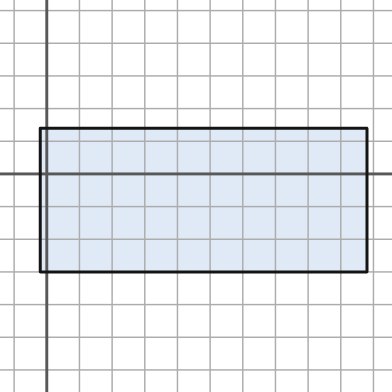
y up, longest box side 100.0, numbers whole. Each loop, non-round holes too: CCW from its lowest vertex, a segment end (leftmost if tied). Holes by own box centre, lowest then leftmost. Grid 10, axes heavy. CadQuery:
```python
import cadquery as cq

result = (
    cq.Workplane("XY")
    .moveTo(-2.0, -30.0)
    .lineTo(98.0, -30.0)
    .lineTo(98.0, 14.0)
    .lineTo(-2.0, 14.0)
    .close()
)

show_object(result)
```